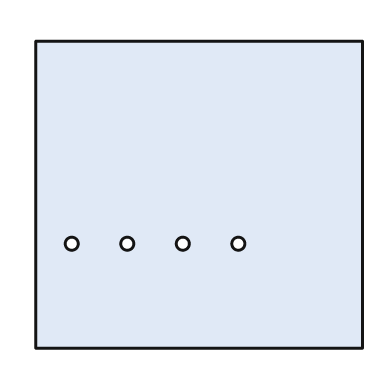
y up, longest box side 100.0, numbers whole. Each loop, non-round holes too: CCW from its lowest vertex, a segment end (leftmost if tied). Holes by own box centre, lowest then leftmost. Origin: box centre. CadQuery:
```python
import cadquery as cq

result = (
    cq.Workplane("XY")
    .moveTo(-50.0, -47.0)
    .lineTo(50.0, -47.0)
    .lineTo(50.0, 47.0)
    .lineTo(-50.0, 47.0)
    .close()
    .moveTo(-39.0, -15.0)
    .circle(2.0)
    .moveTo(-22.0, -15.0)
    .circle(2.0)
    .moveTo(-5.0, -15.0)
    .circle(2.0)
    .moveTo(12.0, -15.0)
    .circle(2.0)
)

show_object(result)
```